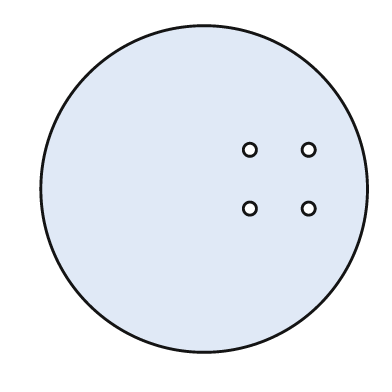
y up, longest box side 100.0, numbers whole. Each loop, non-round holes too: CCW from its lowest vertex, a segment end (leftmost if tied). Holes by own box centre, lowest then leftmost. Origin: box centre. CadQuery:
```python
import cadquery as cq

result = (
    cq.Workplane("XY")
    .moveTo(0.0, 0.0)
    .circle(50.0)
    .moveTo(14.0, -6.0)
    .circle(2.0)
    .moveTo(32.0, -6.0)
    .circle(2.0)
    .moveTo(14.0, 12.0)
    .circle(2.0)
    .moveTo(32.0, 12.0)
    .circle(2.0)
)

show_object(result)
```